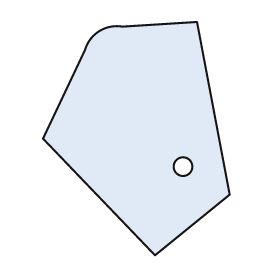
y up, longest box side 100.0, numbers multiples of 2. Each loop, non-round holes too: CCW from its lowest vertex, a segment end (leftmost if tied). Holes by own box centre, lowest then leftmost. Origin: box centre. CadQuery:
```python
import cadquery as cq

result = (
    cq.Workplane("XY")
    .moveTo(8.0, -50.0)
    .lineTo(40.0, -24.0)
    .lineTo(26.0, 50.0)
    .lineTo(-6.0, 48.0)
    .threePointArc((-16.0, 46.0), (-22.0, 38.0))
    .lineTo(-40.0, 0.0)
    .close()
    .moveTo(20.0, -12.0)
    .circle(4.0)
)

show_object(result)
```